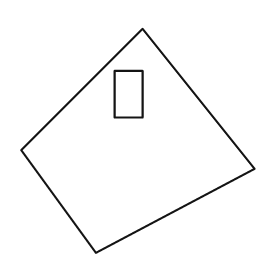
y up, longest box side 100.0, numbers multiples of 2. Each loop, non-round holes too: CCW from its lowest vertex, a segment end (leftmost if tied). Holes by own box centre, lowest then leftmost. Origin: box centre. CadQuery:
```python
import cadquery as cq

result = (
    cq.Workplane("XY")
    .moveTo(-18.0, -48.0)
    .lineTo(50.0, -12.0)
    .lineTo(2.0, 48.0)
    .lineTo(-50.0, -4.0)
    .close()
    .moveTo(-10.0, 10.0)
    .lineTo(2.0, 10.0)
    .lineTo(2.0, 30.0)
    .lineTo(-10.0, 30.0)
    .close()
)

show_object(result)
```